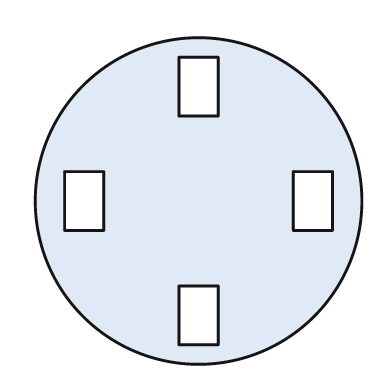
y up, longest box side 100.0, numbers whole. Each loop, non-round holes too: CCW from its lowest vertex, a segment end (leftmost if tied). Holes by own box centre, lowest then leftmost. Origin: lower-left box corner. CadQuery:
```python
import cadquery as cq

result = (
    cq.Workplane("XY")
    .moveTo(50.0, 50.0)
    .circle(50.0)
    .moveTo(44.0, 6.0)
    .lineTo(56.0, 6.0)
    .lineTo(56.0, 24.0)
    .lineTo(44.0, 24.0)
    .close()
    .moveTo(9.0, 41.0)
    .lineTo(21.0, 41.0)
    .lineTo(21.0, 59.0)
    .lineTo(9.0, 59.0)
    .close()
    .moveTo(79.0, 41.0)
    .lineTo(91.0, 41.0)
    .lineTo(91.0, 59.0)
    .lineTo(79.0, 59.0)
    .close()
    .moveTo(44.0, 76.0)
    .lineTo(56.0, 76.0)
    .lineTo(56.0, 94.0)
    .lineTo(44.0, 94.0)
    .close()
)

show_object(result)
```